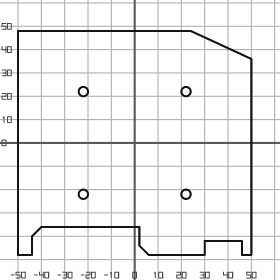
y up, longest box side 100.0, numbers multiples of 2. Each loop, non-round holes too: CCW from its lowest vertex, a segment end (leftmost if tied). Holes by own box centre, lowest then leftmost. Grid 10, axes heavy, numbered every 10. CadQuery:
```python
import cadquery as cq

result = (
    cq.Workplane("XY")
    .moveTo(-50.0, -48.0)
    .lineTo(-44.0, -48.0)
    .lineTo(-44.0, -40.0)
    .lineTo(-40.0, -36.0)
    .lineTo(2.0, -36.0)
    .lineTo(2.0, -44.0)
    .lineTo(6.0, -48.0)
    .lineTo(30.0, -48.0)
    .lineTo(30.0, -42.0)
    .lineTo(46.0, -42.0)
    .lineTo(46.0, -48.0)
    .lineTo(50.0, -48.0)
    .lineTo(50.0, 36.0)
    .lineTo(24.0, 48.0)
    .lineTo(-50.0, 48.0)
    .close()
    .moveTo(-22.0, -22.0)
    .circle(2.0)
    .moveTo(22.0, -22.0)
    .circle(2.0)
    .moveTo(-22.0, 22.0)
    .circle(2.0)
    .moveTo(22.0, 22.0)
    .circle(2.0)
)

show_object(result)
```